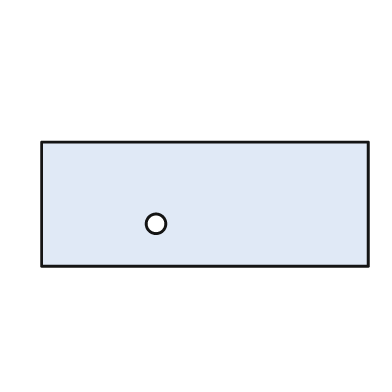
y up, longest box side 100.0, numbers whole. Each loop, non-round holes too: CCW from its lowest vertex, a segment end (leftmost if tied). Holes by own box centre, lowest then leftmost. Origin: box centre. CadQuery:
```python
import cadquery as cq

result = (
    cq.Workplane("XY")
    .moveTo(-50.0, -19.0)
    .lineTo(50.0, -19.0)
    .lineTo(50.0, 19.0)
    .lineTo(-50.0, 19.0)
    .close()
    .moveTo(-15.0, -6.0)
    .circle(3.0)
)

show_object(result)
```